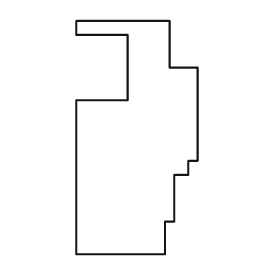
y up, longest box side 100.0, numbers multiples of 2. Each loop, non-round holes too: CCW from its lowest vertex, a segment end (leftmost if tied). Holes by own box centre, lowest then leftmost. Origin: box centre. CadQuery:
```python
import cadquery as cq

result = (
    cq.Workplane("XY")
    .moveTo(-26.0, -50.0)
    .lineTo(12.0, -50.0)
    .lineTo(12.0, -36.0)
    .lineTo(16.0, -36.0)
    .lineTo(16.0, -16.0)
    .lineTo(22.0, -16.0)
    .lineTo(22.0, -10.0)
    .lineTo(26.0, -10.0)
    .lineTo(26.0, 30.0)
    .lineTo(14.0, 30.0)
    .lineTo(14.0, 50.0)
    .lineTo(-26.0, 50.0)
    .lineTo(-26.0, 44.0)
    .lineTo(-4.0, 44.0)
    .lineTo(-4.0, 16.0)
    .lineTo(-26.0, 16.0)
    .close()
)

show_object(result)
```